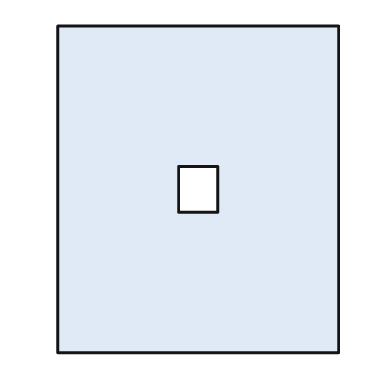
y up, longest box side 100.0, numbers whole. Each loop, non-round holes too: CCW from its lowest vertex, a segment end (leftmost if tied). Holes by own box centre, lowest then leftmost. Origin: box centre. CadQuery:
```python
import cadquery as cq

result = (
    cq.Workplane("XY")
    .moveTo(-43.0, -50.0)
    .lineTo(43.0, -50.0)
    .lineTo(43.0, 50.0)
    .lineTo(-43.0, 50.0)
    .close()
    .moveTo(-6.0, -7.0)
    .lineTo(6.0, -7.0)
    .lineTo(6.0, 7.0)
    .lineTo(-6.0, 7.0)
    .close()
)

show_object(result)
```